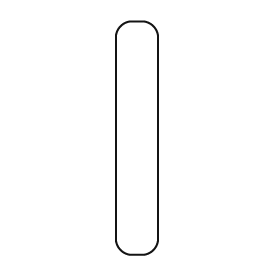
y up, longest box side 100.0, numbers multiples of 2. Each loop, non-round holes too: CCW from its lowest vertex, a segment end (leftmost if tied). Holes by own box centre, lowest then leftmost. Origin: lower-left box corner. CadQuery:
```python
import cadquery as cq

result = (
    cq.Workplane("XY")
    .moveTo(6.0, 0.0)
    .lineTo(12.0, 0.0)
    .threePointArc((16.0, 2.0), (18.0, 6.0))
    .lineTo(18.0, 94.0)
    .threePointArc((16.0, 98.0), (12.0, 100.0))
    .lineTo(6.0, 100.0)
    .threePointArc((2.0, 98.0), (0.0, 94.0))
    .lineTo(0.0, 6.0)
    .threePointArc((2.0, 2.0), (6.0, 0.0))
    .close()
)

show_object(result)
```